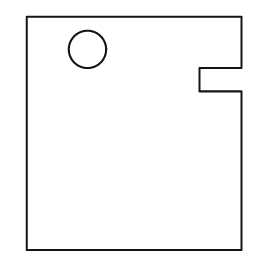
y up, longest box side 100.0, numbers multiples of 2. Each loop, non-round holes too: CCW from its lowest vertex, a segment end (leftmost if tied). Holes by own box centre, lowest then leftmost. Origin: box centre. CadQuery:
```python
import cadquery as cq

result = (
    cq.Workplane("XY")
    .moveTo(-46.0, -50.0)
    .lineTo(46.0, -50.0)
    .lineTo(46.0, 18.0)
    .lineTo(28.0, 18.0)
    .lineTo(28.0, 28.0)
    .lineTo(46.0, 28.0)
    .lineTo(46.0, 50.0)
    .lineTo(-46.0, 50.0)
    .close()
    .moveTo(-20.0, 36.0)
    .circle(8.0)
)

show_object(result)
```